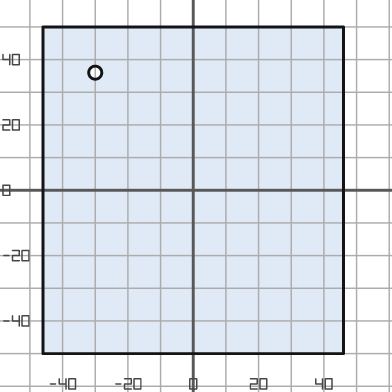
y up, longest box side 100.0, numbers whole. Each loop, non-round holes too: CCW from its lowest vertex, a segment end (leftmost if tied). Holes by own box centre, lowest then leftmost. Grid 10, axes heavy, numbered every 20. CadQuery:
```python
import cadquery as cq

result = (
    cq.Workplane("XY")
    .moveTo(-46.0, -50.0)
    .lineTo(46.0, -50.0)
    .lineTo(46.0, 50.0)
    .lineTo(-46.0, 50.0)
    .close()
    .moveTo(-30.0, 36.0)
    .circle(2.0)
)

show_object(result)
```